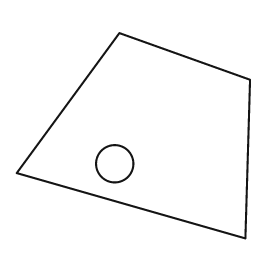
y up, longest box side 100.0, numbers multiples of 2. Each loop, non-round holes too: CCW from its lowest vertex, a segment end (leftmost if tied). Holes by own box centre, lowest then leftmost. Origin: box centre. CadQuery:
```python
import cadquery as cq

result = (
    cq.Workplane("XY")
    .moveTo(48.0, -44.0)
    .lineTo(50.0, 24.0)
    .lineTo(-6.0, 44.0)
    .lineTo(-50.0, -16.0)
    .close()
    .moveTo(-8.0, -12.0)
    .circle(8.0)
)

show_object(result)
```